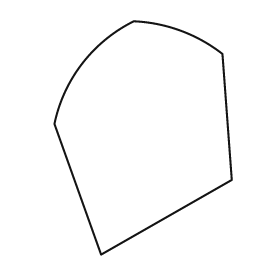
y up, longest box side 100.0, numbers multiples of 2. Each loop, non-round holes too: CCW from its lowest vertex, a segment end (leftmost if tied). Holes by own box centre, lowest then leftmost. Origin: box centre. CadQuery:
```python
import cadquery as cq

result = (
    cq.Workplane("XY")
    .moveTo(-18.0, -50.0)
    .lineTo(38.0, -18.0)
    .lineTo(34.0, 36.0)
    .threePointArc((16.0, 46.0), (-4.0, 50.0))
    .threePointArc((-26.0, 32.0), (-38.0, 6.0))
    .close()
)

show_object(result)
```